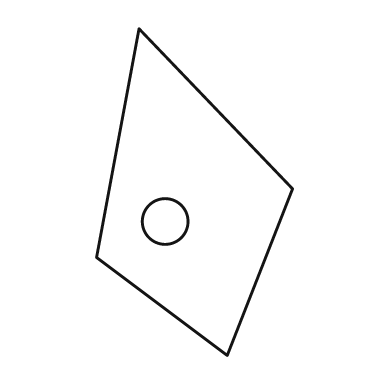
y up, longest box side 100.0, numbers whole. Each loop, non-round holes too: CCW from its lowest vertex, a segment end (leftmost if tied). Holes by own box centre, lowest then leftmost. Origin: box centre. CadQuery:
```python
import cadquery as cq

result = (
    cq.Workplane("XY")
    .moveTo(10.0, -50.0)
    .lineTo(30.0, 1.0)
    .lineTo(-17.0, 50.0)
    .lineTo(-30.0, -20.0)
    .close()
    .moveTo(-9.0, -9.0)
    .circle(7.0)
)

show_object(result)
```